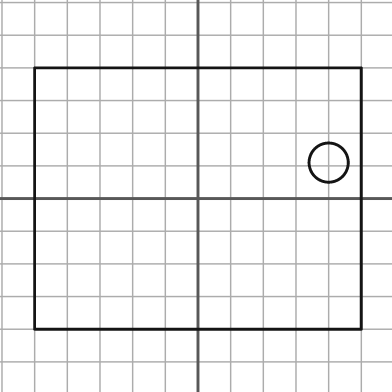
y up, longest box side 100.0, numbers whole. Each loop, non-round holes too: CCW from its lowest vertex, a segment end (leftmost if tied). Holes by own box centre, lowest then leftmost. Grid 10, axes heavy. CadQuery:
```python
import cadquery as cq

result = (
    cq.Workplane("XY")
    .moveTo(-50.0, -40.0)
    .lineTo(50.0, -40.0)
    .lineTo(50.0, 40.0)
    .lineTo(-50.0, 40.0)
    .close()
    .moveTo(40.0, 11.0)
    .circle(6.0)
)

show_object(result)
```